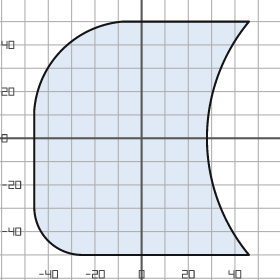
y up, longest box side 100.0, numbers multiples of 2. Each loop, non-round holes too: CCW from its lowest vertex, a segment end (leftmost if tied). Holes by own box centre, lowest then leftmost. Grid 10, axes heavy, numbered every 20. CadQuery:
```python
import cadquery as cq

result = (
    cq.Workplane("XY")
    .moveTo(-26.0, -50.0)
    .lineTo(46.0, -50.0)
    .threePointArc((28.0, 0.0), (46.0, 50.0))
    .lineTo(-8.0, 50.0)
    .threePointArc((-34.0, 38.0), (-46.0, 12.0))
    .lineTo(-46.0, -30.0)
    .threePointArc((-40.0, -44.0), (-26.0, -50.0))
    .close()
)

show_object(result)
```